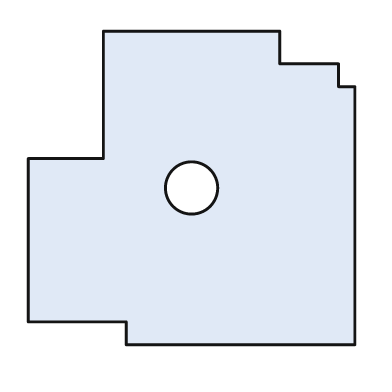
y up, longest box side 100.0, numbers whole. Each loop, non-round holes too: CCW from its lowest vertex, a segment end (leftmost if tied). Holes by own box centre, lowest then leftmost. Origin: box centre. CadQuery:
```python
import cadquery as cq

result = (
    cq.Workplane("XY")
    .moveTo(-20.0, -48.0)
    .lineTo(50.0, -48.0)
    .lineTo(50.0, 31.0)
    .lineTo(45.0, 31.0)
    .lineTo(45.0, 38.0)
    .lineTo(27.0, 38.0)
    .lineTo(27.0, 48.0)
    .lineTo(-27.0, 48.0)
    .lineTo(-27.0, 9.0)
    .lineTo(-50.0, 9.0)
    .lineTo(-50.0, -41.0)
    .lineTo(-20.0, -41.0)
    .close()
    .moveTo(0.0, 0.0)
    .circle(8.0)
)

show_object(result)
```